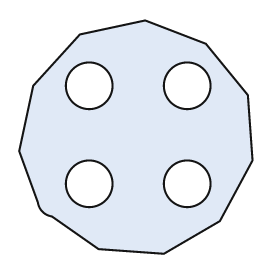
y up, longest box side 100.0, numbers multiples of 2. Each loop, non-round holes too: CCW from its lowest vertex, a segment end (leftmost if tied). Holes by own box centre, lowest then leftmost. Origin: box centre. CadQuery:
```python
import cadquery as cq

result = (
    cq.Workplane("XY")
    .moveTo(12.0, -50.0)
    .lineTo(36.0, -36.0)
    .lineTo(50.0, -10.0)
    .lineTo(48.0, 18.0)
    .lineTo(30.0, 40.0)
    .lineTo(4.0, 50.0)
    .lineTo(-24.0, 44.0)
    .lineTo(-44.0, 22.0)
    .lineTo(-50.0, -6.0)
    .lineTo(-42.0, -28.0)
    .threePointArc((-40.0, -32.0), (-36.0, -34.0))
    .lineTo(-16.0, -48.0)
    .close()
    .moveTo(-20.0, -20.0)
    .circle(10.0)
    .moveTo(22.0, -20.0)
    .circle(10.0)
    .moveTo(-20.0, 22.0)
    .circle(10.0)
    .moveTo(22.0, 22.0)
    .circle(10.0)
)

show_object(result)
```